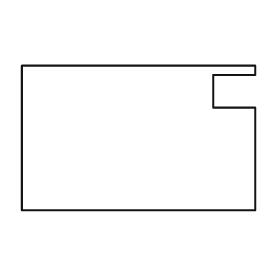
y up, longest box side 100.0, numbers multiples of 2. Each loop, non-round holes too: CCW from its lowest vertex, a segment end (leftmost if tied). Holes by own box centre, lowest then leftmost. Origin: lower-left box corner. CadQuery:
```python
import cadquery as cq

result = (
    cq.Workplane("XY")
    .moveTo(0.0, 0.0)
    .lineTo(100.0, 0.0)
    .lineTo(100.0, 44.0)
    .lineTo(82.0, 44.0)
    .lineTo(82.0, 58.0)
    .lineTo(100.0, 58.0)
    .lineTo(100.0, 62.0)
    .lineTo(0.0, 62.0)
    .close()
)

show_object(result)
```